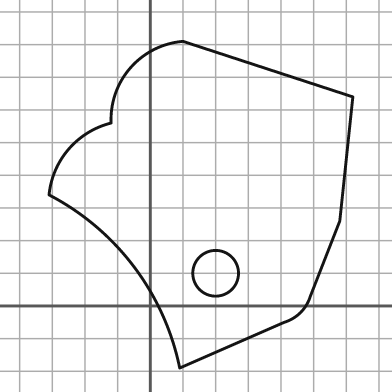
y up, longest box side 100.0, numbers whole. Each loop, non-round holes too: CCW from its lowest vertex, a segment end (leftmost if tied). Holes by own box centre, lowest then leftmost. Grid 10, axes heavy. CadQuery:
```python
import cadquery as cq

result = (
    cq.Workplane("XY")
    .moveTo(9.0, -19.0)
    .lineTo(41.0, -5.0)
    .threePointArc((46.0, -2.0), (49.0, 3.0))
    .lineTo(58.0, 26.0)
    .lineTo(62.0, 64.0)
    .lineTo(10.0, 81.0)
    .threePointArc((-6.0, 73.0), (-12.0, 56.0))
    .threePointArc((-25.0, 48.0), (-31.0, 34.0))
    .threePointArc((-5.0, 12.0), (9.0, -19.0))
    .close()
    .moveTo(20.0, 10.0)
    .circle(7.0)
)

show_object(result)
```